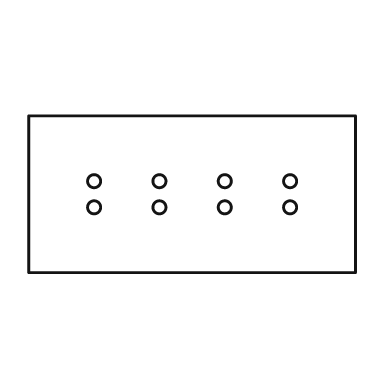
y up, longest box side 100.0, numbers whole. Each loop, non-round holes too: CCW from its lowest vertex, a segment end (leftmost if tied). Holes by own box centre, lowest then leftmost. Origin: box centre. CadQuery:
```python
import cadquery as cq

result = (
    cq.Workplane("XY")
    .moveTo(-50.0, -24.0)
    .lineTo(50.0, -24.0)
    .lineTo(50.0, 24.0)
    .lineTo(-50.0, 24.0)
    .close()
    .moveTo(-30.0, -4.0)
    .circle(2.0)
    .moveTo(-10.0, -4.0)
    .circle(2.0)
    .moveTo(10.0, -4.0)
    .circle(2.0)
    .moveTo(30.0, -4.0)
    .circle(2.0)
    .moveTo(-30.0, 4.0)
    .circle(2.0)
    .moveTo(-10.0, 4.0)
    .circle(2.0)
    .moveTo(10.0, 4.0)
    .circle(2.0)
    .moveTo(30.0, 4.0)
    .circle(2.0)
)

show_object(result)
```